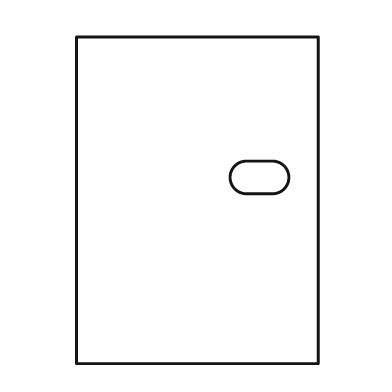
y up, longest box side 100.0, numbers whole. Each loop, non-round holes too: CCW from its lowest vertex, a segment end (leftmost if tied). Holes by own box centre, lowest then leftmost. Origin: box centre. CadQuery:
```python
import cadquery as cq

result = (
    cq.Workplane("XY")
    .moveTo(-37.0, -50.0)
    .lineTo(37.0, -50.0)
    .lineTo(37.0, 50.0)
    .lineTo(-37.0, 50.0)
    .close()
    .moveTo(15.0, 2.0)
    .lineTo(23.0, 2.0)
    .threePointArc((28.0, 7.0), (23.0, 12.0))
    .lineTo(15.0, 12.0)
    .threePointArc((10.0, 7.0), (15.0, 2.0))
    .close()
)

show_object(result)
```